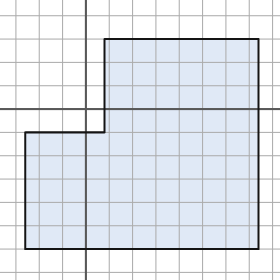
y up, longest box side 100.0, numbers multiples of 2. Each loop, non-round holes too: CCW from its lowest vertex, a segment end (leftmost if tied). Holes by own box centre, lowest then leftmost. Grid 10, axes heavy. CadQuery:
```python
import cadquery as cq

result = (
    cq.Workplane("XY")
    .moveTo(-26.0, -60.0)
    .lineTo(74.0, -60.0)
    .lineTo(74.0, 30.0)
    .lineTo(8.0, 30.0)
    .lineTo(8.0, -10.0)
    .lineTo(-26.0, -10.0)
    .close()
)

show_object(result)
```